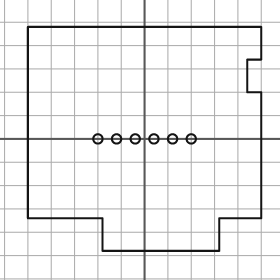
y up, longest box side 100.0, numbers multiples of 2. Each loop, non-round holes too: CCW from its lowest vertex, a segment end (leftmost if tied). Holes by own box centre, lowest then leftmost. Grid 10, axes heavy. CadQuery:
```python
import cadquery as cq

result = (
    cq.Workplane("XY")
    .moveTo(-18.0, -48.0)
    .lineTo(32.0, -48.0)
    .lineTo(32.0, -34.0)
    .lineTo(50.0, -34.0)
    .lineTo(50.0, 20.0)
    .lineTo(44.0, 20.0)
    .lineTo(44.0, 34.0)
    .lineTo(50.0, 34.0)
    .lineTo(50.0, 48.0)
    .lineTo(-50.0, 48.0)
    .lineTo(-50.0, -34.0)
    .lineTo(-18.0, -34.0)
    .close()
    .moveTo(-20.0, 0.0)
    .circle(2.0)
    .moveTo(-12.0, 0.0)
    .circle(2.0)
    .moveTo(-4.0, 0.0)
    .circle(2.0)
    .moveTo(4.0, 0.0)
    .circle(2.0)
    .moveTo(12.0, 0.0)
    .circle(2.0)
    .moveTo(20.0, 0.0)
    .circle(2.0)
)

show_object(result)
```